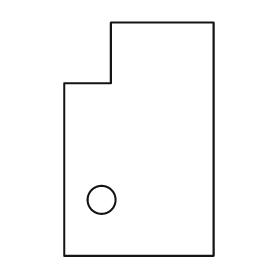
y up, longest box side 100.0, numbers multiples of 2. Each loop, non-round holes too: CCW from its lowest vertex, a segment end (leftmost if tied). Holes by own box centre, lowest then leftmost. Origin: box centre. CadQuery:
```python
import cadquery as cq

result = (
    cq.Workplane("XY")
    .moveTo(-32.0, -50.0)
    .lineTo(32.0, -50.0)
    .lineTo(32.0, 50.0)
    .lineTo(-12.0, 50.0)
    .lineTo(-12.0, 24.0)
    .lineTo(-32.0, 24.0)
    .close()
    .moveTo(-16.0, -26.0)
    .circle(6.0)
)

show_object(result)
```